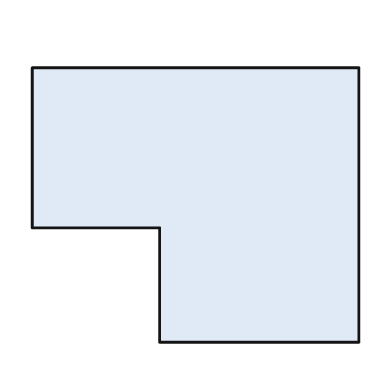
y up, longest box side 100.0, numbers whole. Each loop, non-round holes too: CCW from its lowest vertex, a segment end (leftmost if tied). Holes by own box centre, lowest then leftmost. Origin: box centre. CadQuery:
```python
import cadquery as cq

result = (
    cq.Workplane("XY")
    .moveTo(-11.0, -42.0)
    .lineTo(50.0, -42.0)
    .lineTo(50.0, 42.0)
    .lineTo(-50.0, 42.0)
    .lineTo(-50.0, -7.0)
    .lineTo(-11.0, -7.0)
    .close()
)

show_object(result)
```